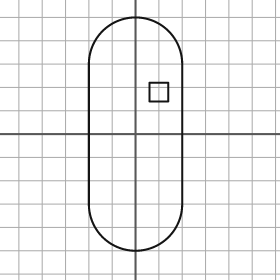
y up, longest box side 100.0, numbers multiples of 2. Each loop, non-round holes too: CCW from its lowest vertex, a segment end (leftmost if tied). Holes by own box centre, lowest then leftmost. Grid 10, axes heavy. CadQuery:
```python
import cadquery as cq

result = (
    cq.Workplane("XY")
    .moveTo(-20.0, -30.0)
    .threePointArc((0.0, -50.0), (20.0, -30.0))
    .lineTo(20.0, 30.0)
    .threePointArc((0.0, 50.0), (-20.0, 30.0))
    .close()
    .moveTo(6.0, 14.0)
    .lineTo(14.0, 14.0)
    .lineTo(14.0, 22.0)
    .lineTo(6.0, 22.0)
    .close()
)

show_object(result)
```